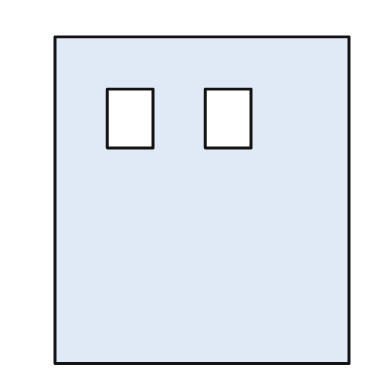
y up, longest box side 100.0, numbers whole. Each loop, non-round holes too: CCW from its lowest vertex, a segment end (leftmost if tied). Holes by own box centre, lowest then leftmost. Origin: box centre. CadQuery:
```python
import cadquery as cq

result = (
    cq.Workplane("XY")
    .moveTo(-45.0, -50.0)
    .lineTo(45.0, -50.0)
    .lineTo(45.0, 50.0)
    .lineTo(-45.0, 50.0)
    .close()
    .moveTo(-29.0, 16.0)
    .lineTo(-15.0, 16.0)
    .lineTo(-15.0, 34.0)
    .lineTo(-29.0, 34.0)
    .close()
    .moveTo(1.0, 16.0)
    .lineTo(15.0, 16.0)
    .lineTo(15.0, 34.0)
    .lineTo(1.0, 34.0)
    .close()
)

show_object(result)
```